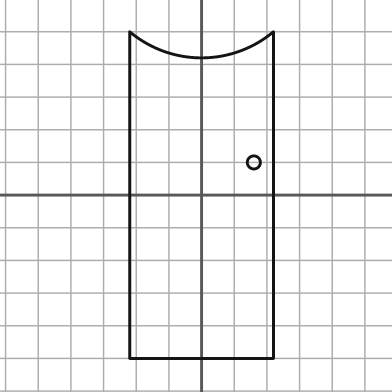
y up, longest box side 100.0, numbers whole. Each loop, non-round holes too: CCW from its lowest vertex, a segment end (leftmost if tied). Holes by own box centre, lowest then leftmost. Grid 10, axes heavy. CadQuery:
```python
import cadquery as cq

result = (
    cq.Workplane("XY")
    .moveTo(-22.0, -50.0)
    .lineTo(22.0, -50.0)
    .lineTo(22.0, 50.0)
    .threePointArc((0.0, 42.0), (-22.0, 50.0))
    .close()
    .moveTo(16.0, 10.0)
    .circle(2.0)
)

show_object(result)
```